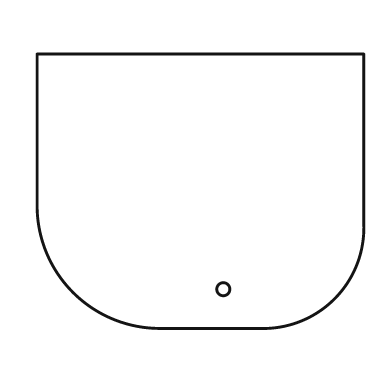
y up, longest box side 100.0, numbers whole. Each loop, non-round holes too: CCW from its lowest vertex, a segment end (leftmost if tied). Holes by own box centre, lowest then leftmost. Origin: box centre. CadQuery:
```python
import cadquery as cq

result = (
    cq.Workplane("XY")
    .moveTo(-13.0, -42.0)
    .lineTo(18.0, -42.0)
    .threePointArc((41.0, -33.0), (50.0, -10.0))
    .lineTo(50.0, 42.0)
    .lineTo(-50.0, 42.0)
    .lineTo(-50.0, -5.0)
    .threePointArc((-39.0, -31.0), (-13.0, -42.0))
    .close()
    .moveTo(7.0, -30.0)
    .circle(2.0)
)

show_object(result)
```